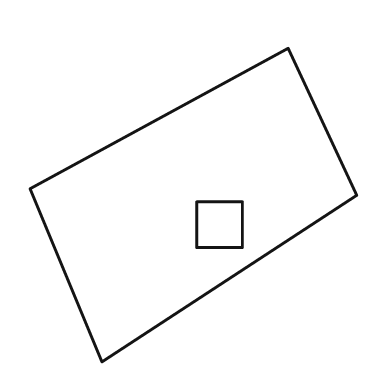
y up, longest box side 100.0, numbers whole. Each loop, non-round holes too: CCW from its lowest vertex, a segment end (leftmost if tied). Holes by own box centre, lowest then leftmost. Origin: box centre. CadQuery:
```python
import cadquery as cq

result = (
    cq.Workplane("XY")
    .moveTo(-28.0, -48.0)
    .lineTo(50.0, 3.0)
    .lineTo(29.0, 48.0)
    .lineTo(-50.0, 5.0)
    .close()
    .moveTo(1.0, -13.0)
    .lineTo(15.0, -13.0)
    .lineTo(15.0, 1.0)
    .lineTo(1.0, 1.0)
    .close()
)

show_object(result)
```